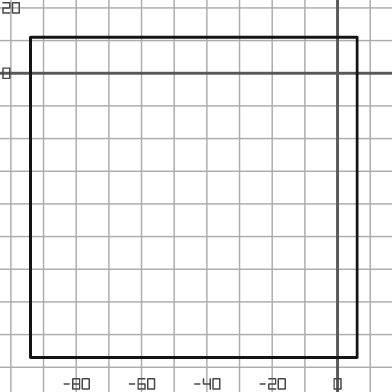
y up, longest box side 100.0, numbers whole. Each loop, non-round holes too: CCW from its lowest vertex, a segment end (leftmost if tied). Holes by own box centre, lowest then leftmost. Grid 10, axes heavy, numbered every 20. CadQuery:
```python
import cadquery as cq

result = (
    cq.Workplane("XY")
    .moveTo(-94.0, -87.0)
    .lineTo(6.0, -87.0)
    .lineTo(6.0, 11.0)
    .lineTo(-94.0, 11.0)
    .close()
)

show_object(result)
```